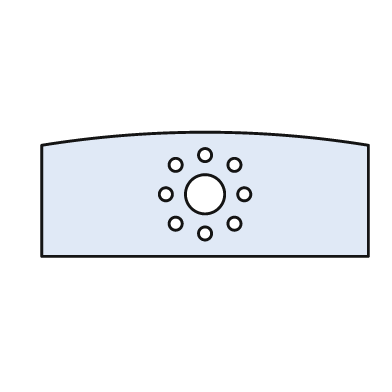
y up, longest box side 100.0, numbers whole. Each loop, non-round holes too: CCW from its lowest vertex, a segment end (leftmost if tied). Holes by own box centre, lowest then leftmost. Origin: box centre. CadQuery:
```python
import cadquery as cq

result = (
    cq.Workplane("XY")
    .moveTo(-50.0, -19.0)
    .lineTo(50.0, -19.0)
    .lineTo(50.0, 15.0)
    .threePointArc((0.0, 19.0), (-50.0, 15.0))
    .close()
    .moveTo(0.0, -12.0)
    .circle(2.0)
    .moveTo(-9.0, -9.0)
    .circle(2.0)
    .moveTo(9.0, -9.0)
    .circle(2.0)
    .moveTo(-12.0, 0.0)
    .circle(2.0)
    .moveTo(0.0, 0.0)
    .circle(6.0)
    .moveTo(12.0, 0.0)
    .circle(2.0)
    .moveTo(-9.0, 9.0)
    .circle(2.0)
    .moveTo(9.0, 9.0)
    .circle(2.0)
    .moveTo(0.0, 12.0)
    .circle(2.0)
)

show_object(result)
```